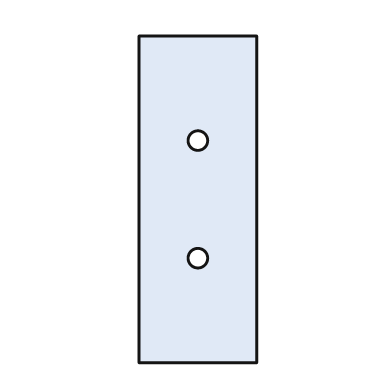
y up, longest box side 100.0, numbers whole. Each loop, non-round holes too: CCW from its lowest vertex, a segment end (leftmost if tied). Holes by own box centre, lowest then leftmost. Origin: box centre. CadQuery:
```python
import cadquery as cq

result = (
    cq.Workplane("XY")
    .moveTo(-18.0, -50.0)
    .lineTo(18.0, -50.0)
    .lineTo(18.0, 50.0)
    .lineTo(-18.0, 50.0)
    .close()
    .moveTo(0.0, -18.0)
    .circle(3.0)
    .moveTo(0.0, 18.0)
    .circle(3.0)
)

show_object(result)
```